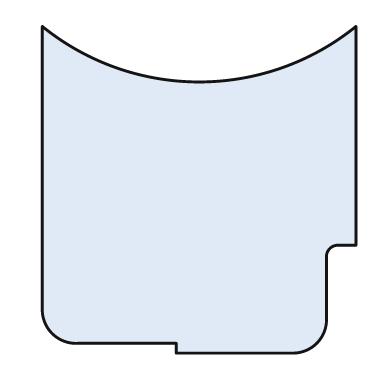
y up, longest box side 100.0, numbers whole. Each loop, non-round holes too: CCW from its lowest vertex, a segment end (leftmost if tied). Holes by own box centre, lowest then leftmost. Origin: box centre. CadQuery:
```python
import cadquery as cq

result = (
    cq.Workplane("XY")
    .moveTo(-7.0, -50.0)
    .lineTo(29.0, -50.0)
    .threePointArc((36.0, -47.0), (39.0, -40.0))
    .lineTo(39.0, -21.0)
    .threePointArc((40.0, -18.0), (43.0, -17.0))
    .lineTo(48.0, -17.0)
    .lineTo(48.0, 50.0)
    .threePointArc((0.0, 33.0), (-48.0, 50.0))
    .lineTo(-48.0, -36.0)
    .threePointArc((-45.0, -44.0), (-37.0, -47.0))
    .lineTo(-7.0, -47.0)
    .close()
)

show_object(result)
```